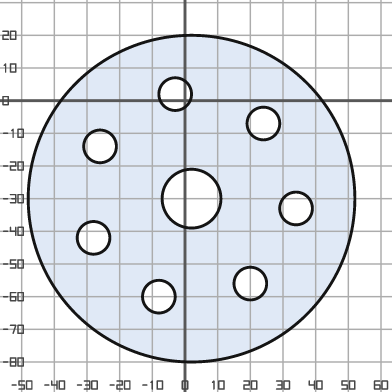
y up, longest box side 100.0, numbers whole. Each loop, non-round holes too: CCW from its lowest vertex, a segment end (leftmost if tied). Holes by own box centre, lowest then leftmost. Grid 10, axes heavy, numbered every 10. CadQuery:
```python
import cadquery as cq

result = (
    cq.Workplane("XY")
    .moveTo(2.0, -30.0)
    .circle(50.0)
    .moveTo(-8.0, -60.0)
    .circle(5.0)
    .moveTo(20.0, -56.0)
    .circle(5.0)
    .moveTo(-28.0, -42.0)
    .circle(5.0)
    .moveTo(34.0, -33.0)
    .circle(5.0)
    .moveTo(2.0, -30.0)
    .circle(9.0)
    .moveTo(-26.0, -14.0)
    .circle(5.0)
    .moveTo(24.0, -7.0)
    .circle(5.0)
    .moveTo(-3.0, 2.0)
    .circle(5.0)
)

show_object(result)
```